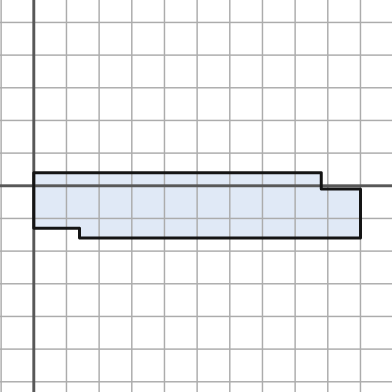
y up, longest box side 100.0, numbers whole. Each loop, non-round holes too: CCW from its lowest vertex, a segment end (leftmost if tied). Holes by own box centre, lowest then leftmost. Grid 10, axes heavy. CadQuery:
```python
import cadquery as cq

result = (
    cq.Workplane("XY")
    .moveTo(14.0, -16.0)
    .lineTo(100.0, -16.0)
    .lineTo(100.0, -1.0)
    .lineTo(88.0, -1.0)
    .lineTo(88.0, 4.0)
    .lineTo(0.0, 4.0)
    .lineTo(0.0, -13.0)
    .lineTo(14.0, -13.0)
    .close()
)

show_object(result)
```